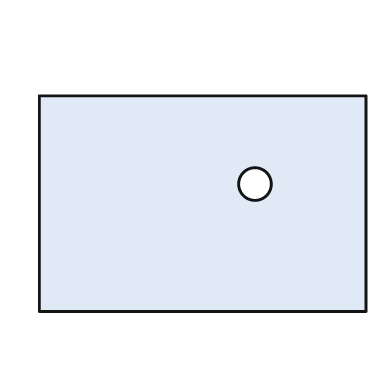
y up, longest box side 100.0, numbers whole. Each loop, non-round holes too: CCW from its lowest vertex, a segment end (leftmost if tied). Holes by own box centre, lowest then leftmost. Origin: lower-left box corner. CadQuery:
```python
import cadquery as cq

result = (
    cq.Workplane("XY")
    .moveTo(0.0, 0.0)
    .lineTo(100.0, 0.0)
    .lineTo(100.0, 66.0)
    .lineTo(0.0, 66.0)
    .close()
    .moveTo(66.0, 39.0)
    .circle(5.0)
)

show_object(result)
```